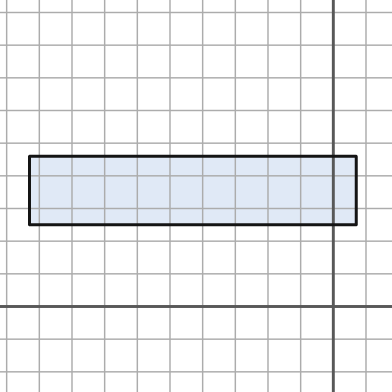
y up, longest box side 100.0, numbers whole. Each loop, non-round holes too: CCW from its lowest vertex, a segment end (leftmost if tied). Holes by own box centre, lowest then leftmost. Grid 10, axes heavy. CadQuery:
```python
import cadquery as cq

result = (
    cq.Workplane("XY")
    .moveTo(-93.0, 25.0)
    .lineTo(7.0, 25.0)
    .lineTo(7.0, 46.0)
    .lineTo(-93.0, 46.0)
    .close()
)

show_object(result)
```